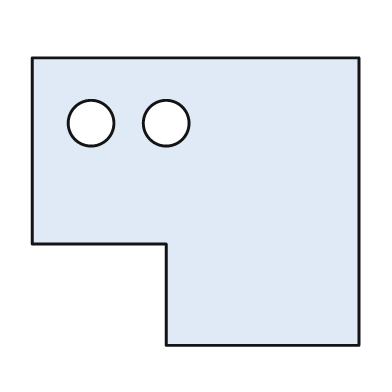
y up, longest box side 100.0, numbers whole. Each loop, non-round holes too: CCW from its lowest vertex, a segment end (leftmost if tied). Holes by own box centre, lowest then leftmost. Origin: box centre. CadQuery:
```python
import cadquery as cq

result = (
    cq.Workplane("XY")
    .moveTo(-9.0, -44.0)
    .lineTo(50.0, -44.0)
    .lineTo(50.0, 44.0)
    .lineTo(-50.0, 44.0)
    .lineTo(-50.0, -13.0)
    .lineTo(-9.0, -13.0)
    .close()
    .moveTo(-32.0, 24.0)
    .circle(7.0)
    .moveTo(-9.0, 24.0)
    .circle(7.0)
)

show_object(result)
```